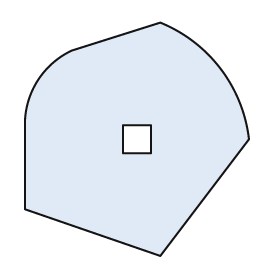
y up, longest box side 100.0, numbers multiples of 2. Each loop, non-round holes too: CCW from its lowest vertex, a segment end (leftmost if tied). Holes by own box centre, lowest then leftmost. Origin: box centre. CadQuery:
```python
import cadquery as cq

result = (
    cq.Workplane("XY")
    .moveTo(10.0, -50.0)
    .lineTo(48.0, 0.0)
    .threePointArc((36.0, 30.0), (10.0, 50.0))
    .lineTo(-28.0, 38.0)
    .threePointArc((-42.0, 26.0), (-48.0, 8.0))
    .lineTo(-48.0, -30.0)
    .close()
    .moveTo(-6.0, -6.0)
    .lineTo(6.0, -6.0)
    .lineTo(6.0, 6.0)
    .lineTo(-6.0, 6.0)
    .close()
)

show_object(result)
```